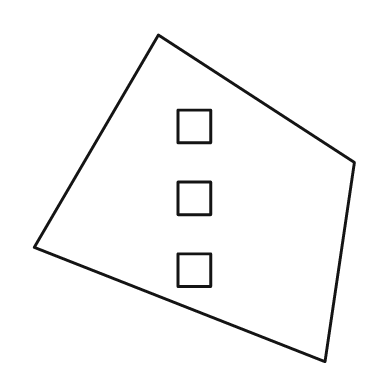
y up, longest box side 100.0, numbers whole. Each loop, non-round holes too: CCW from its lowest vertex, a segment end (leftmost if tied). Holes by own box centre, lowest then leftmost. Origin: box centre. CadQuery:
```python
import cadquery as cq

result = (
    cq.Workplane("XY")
    .moveTo(40.0, -50.0)
    .lineTo(49.0, 11.0)
    .lineTo(-11.0, 50.0)
    .lineTo(-49.0, -15.0)
    .close()
    .moveTo(-5.0, -27.0)
    .lineTo(5.0, -27.0)
    .lineTo(5.0, -17.0)
    .lineTo(-5.0, -17.0)
    .close()
    .moveTo(-5.0, -5.0)
    .lineTo(5.0, -5.0)
    .lineTo(5.0, 5.0)
    .lineTo(-5.0, 5.0)
    .close()
    .moveTo(-5.0, 17.0)
    .lineTo(5.0, 17.0)
    .lineTo(5.0, 27.0)
    .lineTo(-5.0, 27.0)
    .close()
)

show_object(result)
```